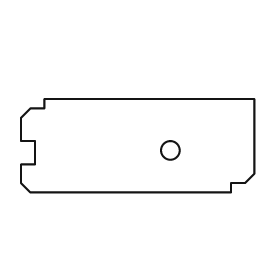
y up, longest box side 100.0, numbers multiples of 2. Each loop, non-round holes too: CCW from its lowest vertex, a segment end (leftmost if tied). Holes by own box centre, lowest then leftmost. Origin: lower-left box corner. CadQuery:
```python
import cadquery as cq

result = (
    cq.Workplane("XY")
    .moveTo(4.0, 0.0)
    .lineTo(90.0, 0.0)
    .lineTo(90.0, 4.0)
    .lineTo(96.0, 4.0)
    .lineTo(100.0, 8.0)
    .lineTo(100.0, 40.0)
    .lineTo(10.0, 40.0)
    .lineTo(10.0, 36.0)
    .lineTo(4.0, 36.0)
    .lineTo(0.0, 32.0)
    .lineTo(0.0, 22.0)
    .lineTo(6.0, 22.0)
    .lineTo(6.0, 12.0)
    .lineTo(0.0, 12.0)
    .lineTo(0.0, 4.0)
    .close()
    .moveTo(64.0, 18.0)
    .circle(4.0)
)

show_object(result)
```